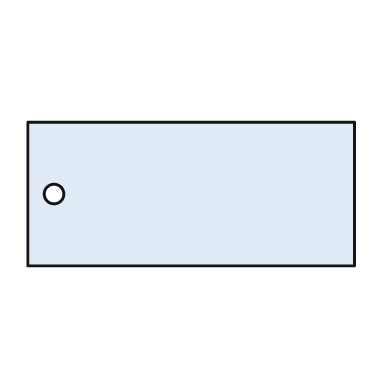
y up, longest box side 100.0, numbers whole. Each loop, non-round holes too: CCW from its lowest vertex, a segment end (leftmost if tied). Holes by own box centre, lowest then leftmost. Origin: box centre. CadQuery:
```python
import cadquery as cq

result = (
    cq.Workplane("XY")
    .moveTo(-50.0, -22.0)
    .lineTo(50.0, -22.0)
    .lineTo(50.0, 22.0)
    .lineTo(-50.0, 22.0)
    .close()
    .moveTo(-42.0, 0.0)
    .circle(3.0)
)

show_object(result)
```